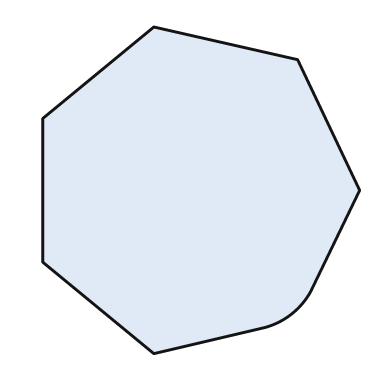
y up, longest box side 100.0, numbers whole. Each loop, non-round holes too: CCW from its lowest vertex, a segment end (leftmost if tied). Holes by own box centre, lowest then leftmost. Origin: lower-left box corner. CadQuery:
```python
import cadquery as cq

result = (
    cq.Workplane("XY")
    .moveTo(34.0, 0.0)
    .lineTo(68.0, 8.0)
    .threePointArc((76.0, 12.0), (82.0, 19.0))
    .lineTo(97.0, 50.0)
    .lineTo(78.0, 90.0)
    .lineTo(34.0, 100.0)
    .lineTo(0.0, 72.0)
    .lineTo(0.0, 28.0)
    .close()
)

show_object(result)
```